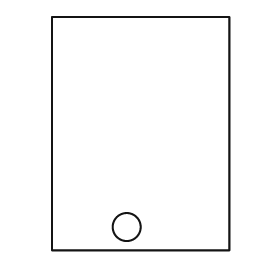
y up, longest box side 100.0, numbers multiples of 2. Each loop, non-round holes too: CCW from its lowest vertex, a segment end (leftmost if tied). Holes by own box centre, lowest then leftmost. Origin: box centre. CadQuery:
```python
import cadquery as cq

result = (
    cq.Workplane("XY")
    .moveTo(-38.0, -50.0)
    .lineTo(38.0, -50.0)
    .lineTo(38.0, 50.0)
    .lineTo(-38.0, 50.0)
    .close()
    .moveTo(-6.0, -40.0)
    .circle(6.0)
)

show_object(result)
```